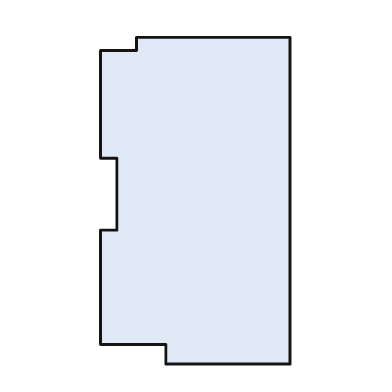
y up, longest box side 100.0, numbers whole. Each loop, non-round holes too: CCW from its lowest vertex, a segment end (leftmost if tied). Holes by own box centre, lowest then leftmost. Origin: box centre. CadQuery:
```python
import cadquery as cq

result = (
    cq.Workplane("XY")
    .moveTo(-9.0, -50.0)
    .lineTo(29.0, -50.0)
    .lineTo(29.0, 50.0)
    .lineTo(-18.0, 50.0)
    .lineTo(-18.0, 46.0)
    .lineTo(-29.0, 46.0)
    .lineTo(-29.0, 13.0)
    .lineTo(-24.0, 13.0)
    .lineTo(-24.0, -9.0)
    .lineTo(-29.0, -9.0)
    .lineTo(-29.0, -44.0)
    .lineTo(-9.0, -44.0)
    .close()
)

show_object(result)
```